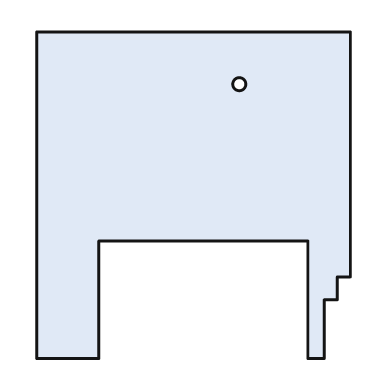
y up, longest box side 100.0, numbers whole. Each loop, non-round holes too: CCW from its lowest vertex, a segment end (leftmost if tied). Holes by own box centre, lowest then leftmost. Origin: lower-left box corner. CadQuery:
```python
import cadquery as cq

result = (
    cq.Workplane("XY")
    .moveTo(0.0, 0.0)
    .lineTo(19.0, 0.0)
    .lineTo(19.0, 36.0)
    .lineTo(83.0, 36.0)
    .lineTo(83.0, 0.0)
    .lineTo(88.0, 0.0)
    .lineTo(88.0, 18.0)
    .lineTo(92.0, 18.0)
    .lineTo(92.0, 25.0)
    .lineTo(96.0, 25.0)
    .lineTo(96.0, 100.0)
    .lineTo(0.0, 100.0)
    .close()
    .moveTo(62.0, 84.0)
    .circle(2.0)
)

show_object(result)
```